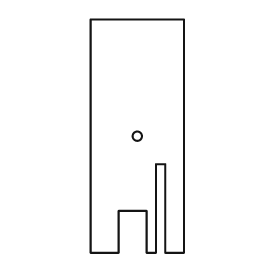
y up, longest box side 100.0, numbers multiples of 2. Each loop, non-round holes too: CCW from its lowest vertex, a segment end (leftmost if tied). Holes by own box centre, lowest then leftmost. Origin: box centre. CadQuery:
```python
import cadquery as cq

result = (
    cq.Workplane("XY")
    .moveTo(-20.0, -50.0)
    .lineTo(-8.0, -50.0)
    .lineTo(-8.0, -32.0)
    .lineTo(4.0, -32.0)
    .lineTo(4.0, -50.0)
    .lineTo(8.0, -50.0)
    .lineTo(8.0, -12.0)
    .lineTo(12.0, -12.0)
    .lineTo(12.0, -50.0)
    .lineTo(20.0, -50.0)
    .lineTo(20.0, 50.0)
    .lineTo(-20.0, 50.0)
    .close()
    .moveTo(0.0, 0.0)
    .circle(2.0)
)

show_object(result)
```